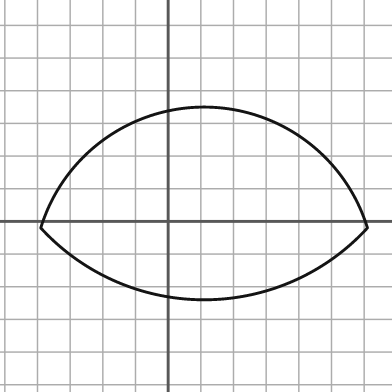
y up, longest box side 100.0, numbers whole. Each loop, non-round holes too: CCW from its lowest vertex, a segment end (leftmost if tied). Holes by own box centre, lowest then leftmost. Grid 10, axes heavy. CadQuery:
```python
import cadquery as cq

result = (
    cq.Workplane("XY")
    .moveTo(-39.0, -2.0)
    .threePointArc((11.0, -24.0), (61.0, -2.0))
    .threePointArc((11.0, 35.0), (-39.0, -2.0))
    .close()
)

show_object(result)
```